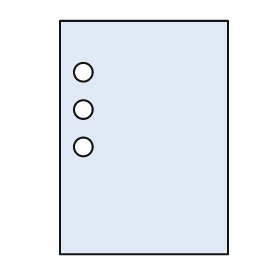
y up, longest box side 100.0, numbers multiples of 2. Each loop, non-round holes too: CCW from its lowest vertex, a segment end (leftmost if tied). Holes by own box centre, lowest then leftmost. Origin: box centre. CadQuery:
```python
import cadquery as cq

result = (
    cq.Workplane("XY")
    .moveTo(-36.0, -50.0)
    .lineTo(36.0, -50.0)
    .lineTo(36.0, 50.0)
    .lineTo(-36.0, 50.0)
    .close()
    .moveTo(-26.0, -4.0)
    .circle(4.0)
    .moveTo(-26.0, 12.0)
    .circle(4.0)
    .moveTo(-26.0, 28.0)
    .circle(4.0)
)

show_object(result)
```